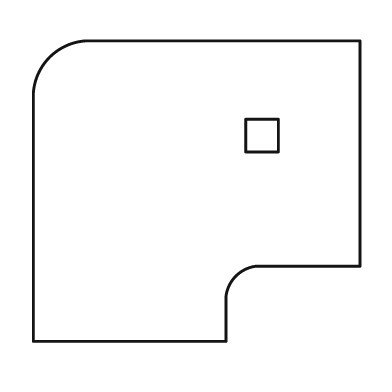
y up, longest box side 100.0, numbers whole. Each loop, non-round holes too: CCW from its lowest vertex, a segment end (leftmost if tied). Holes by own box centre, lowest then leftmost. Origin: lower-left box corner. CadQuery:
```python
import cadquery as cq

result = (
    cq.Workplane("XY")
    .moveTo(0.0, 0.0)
    .lineTo(59.0, 0.0)
    .lineTo(59.0, 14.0)
    .threePointArc((62.0, 20.0), (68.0, 23.0))
    .lineTo(100.0, 23.0)
    .lineTo(100.0, 92.0)
    .lineTo(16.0, 92.0)
    .threePointArc((5.0, 87.0), (0.0, 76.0))
    .close()
    .moveTo(65.0, 58.0)
    .lineTo(75.0, 58.0)
    .lineTo(75.0, 68.0)
    .lineTo(65.0, 68.0)
    .close()
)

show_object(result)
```